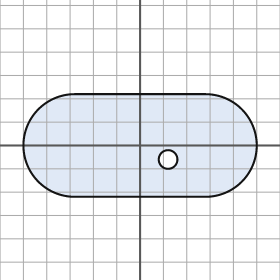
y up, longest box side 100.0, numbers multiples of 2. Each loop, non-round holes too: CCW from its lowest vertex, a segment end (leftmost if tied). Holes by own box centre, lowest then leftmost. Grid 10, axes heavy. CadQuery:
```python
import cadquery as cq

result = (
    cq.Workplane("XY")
    .moveTo(-28.0, -22.0)
    .lineTo(28.0, -22.0)
    .threePointArc((50.0, 0.0), (28.0, 22.0))
    .lineTo(-28.0, 22.0)
    .threePointArc((-50.0, 0.0), (-28.0, -22.0))
    .close()
    .moveTo(12.0, -6.0)
    .circle(4.0)
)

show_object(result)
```